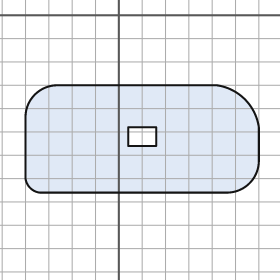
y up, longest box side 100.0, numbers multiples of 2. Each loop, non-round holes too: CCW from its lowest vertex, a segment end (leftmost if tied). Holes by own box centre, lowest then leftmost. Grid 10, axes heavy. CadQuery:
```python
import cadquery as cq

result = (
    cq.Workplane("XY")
    .moveTo(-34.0, -76.0)
    .lineTo(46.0, -76.0)
    .threePointArc((56.0, -72.0), (60.0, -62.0))
    .lineTo(60.0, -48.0)
    .threePointArc((54.0, -36.0), (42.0, -30.0))
    .lineTo(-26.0, -30.0)
    .threePointArc((-36.0, -34.0), (-40.0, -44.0))
    .lineTo(-40.0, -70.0)
    .threePointArc((-38.0, -74.0), (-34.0, -76.0))
    .close()
    .moveTo(4.0, -56.0)
    .lineTo(16.0, -56.0)
    .lineTo(16.0, -48.0)
    .lineTo(4.0, -48.0)
    .close()
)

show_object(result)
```